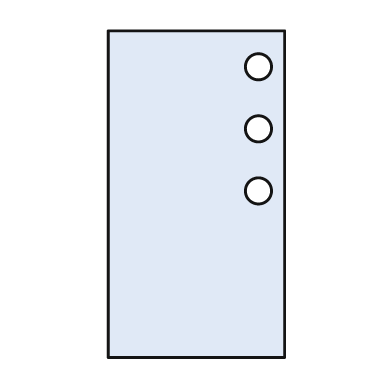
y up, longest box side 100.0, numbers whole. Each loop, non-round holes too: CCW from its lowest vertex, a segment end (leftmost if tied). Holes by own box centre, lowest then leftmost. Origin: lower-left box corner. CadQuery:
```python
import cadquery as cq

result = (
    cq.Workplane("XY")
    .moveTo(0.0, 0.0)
    .lineTo(54.0, 0.0)
    .lineTo(54.0, 100.0)
    .lineTo(0.0, 100.0)
    .close()
    .moveTo(46.0, 51.0)
    .circle(4.0)
    .moveTo(46.0, 70.0)
    .circle(4.0)
    .moveTo(46.0, 89.0)
    .circle(4.0)
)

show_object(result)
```